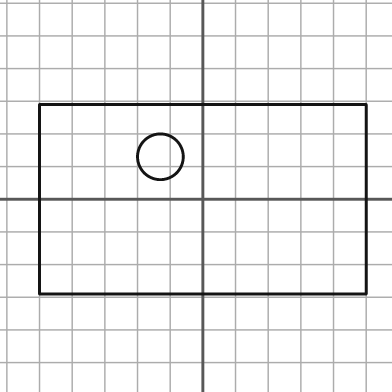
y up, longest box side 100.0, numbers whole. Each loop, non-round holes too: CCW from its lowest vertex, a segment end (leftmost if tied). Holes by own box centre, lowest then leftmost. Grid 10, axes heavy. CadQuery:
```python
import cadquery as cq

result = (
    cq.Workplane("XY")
    .moveTo(-50.0, -29.0)
    .lineTo(50.0, -29.0)
    .lineTo(50.0, 29.0)
    .lineTo(-50.0, 29.0)
    .close()
    .moveTo(-13.0, 13.0)
    .circle(7.0)
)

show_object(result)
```